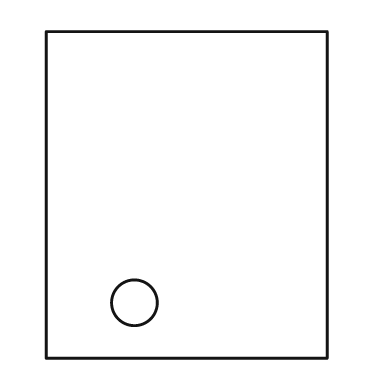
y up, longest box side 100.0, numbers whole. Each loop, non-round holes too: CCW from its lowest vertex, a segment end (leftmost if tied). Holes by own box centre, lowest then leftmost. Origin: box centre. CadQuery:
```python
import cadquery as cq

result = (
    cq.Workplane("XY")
    .moveTo(-43.0, -50.0)
    .lineTo(43.0, -50.0)
    .lineTo(43.0, 50.0)
    .lineTo(-43.0, 50.0)
    .close()
    .moveTo(-16.0, -33.0)
    .circle(7.0)
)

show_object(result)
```